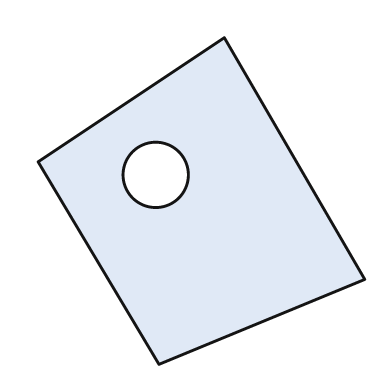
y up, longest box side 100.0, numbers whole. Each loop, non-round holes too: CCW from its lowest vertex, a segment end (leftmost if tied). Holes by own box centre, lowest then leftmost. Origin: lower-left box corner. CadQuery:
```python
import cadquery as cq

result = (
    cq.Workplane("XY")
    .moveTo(37.0, 0.0)
    .lineTo(100.0, 26.0)
    .lineTo(57.0, 100.0)
    .lineTo(0.0, 62.0)
    .close()
    .moveTo(36.0, 58.0)
    .circle(10.0)
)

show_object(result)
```